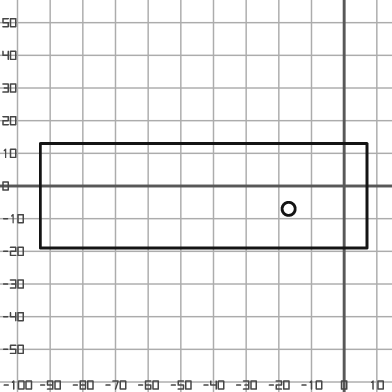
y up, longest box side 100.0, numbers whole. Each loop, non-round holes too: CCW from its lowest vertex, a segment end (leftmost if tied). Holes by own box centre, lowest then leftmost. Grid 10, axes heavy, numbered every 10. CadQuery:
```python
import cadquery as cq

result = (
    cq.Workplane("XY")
    .moveTo(-93.0, -19.0)
    .lineTo(7.0, -19.0)
    .lineTo(7.0, 13.0)
    .lineTo(-93.0, 13.0)
    .close()
    .moveTo(-17.0, -7.0)
    .circle(2.0)
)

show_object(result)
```